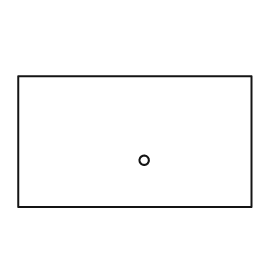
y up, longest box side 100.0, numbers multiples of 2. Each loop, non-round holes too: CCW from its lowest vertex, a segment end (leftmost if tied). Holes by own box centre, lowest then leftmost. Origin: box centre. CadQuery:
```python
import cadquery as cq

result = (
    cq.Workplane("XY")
    .moveTo(-50.0, -28.0)
    .lineTo(50.0, -28.0)
    .lineTo(50.0, 28.0)
    .lineTo(-50.0, 28.0)
    .close()
    .moveTo(4.0, -8.0)
    .circle(2.0)
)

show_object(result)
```